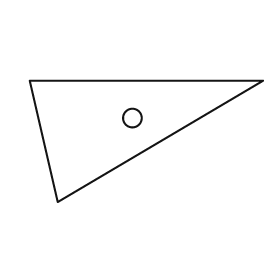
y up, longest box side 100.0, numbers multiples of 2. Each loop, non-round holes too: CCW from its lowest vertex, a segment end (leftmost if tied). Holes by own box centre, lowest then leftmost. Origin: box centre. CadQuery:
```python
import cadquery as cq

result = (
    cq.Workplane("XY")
    .moveTo(-38.0, -26.0)
    .lineTo(50.0, 26.0)
    .lineTo(-50.0, 26.0)
    .close()
    .moveTo(-6.0, 10.0)
    .circle(4.0)
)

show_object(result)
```